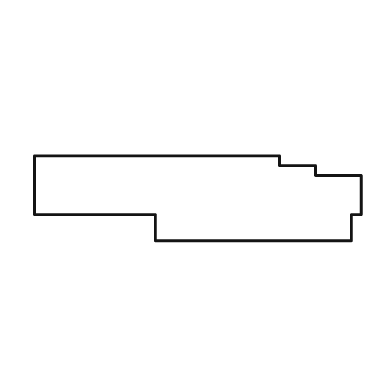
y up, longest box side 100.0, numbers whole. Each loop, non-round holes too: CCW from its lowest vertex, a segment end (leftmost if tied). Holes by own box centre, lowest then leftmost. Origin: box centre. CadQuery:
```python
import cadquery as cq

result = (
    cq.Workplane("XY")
    .moveTo(-13.0, -13.0)
    .lineTo(47.0, -13.0)
    .lineTo(47.0, -5.0)
    .lineTo(50.0, -5.0)
    .lineTo(50.0, 7.0)
    .lineTo(36.0, 7.0)
    .lineTo(36.0, 10.0)
    .lineTo(25.0, 10.0)
    .lineTo(25.0, 13.0)
    .lineTo(-50.0, 13.0)
    .lineTo(-50.0, -5.0)
    .lineTo(-13.0, -5.0)
    .close()
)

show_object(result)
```